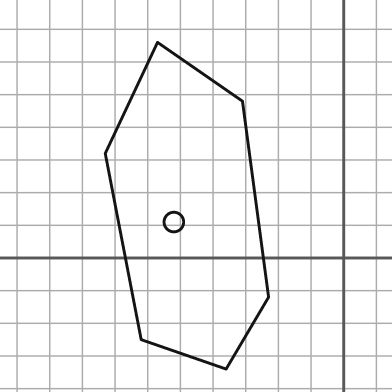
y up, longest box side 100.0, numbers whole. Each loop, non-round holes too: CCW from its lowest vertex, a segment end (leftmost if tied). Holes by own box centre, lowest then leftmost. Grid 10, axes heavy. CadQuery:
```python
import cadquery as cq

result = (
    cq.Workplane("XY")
    .moveTo(-36.0, -34.0)
    .lineTo(-23.0, -12.0)
    .lineTo(-31.0, 48.0)
    .lineTo(-57.0, 66.0)
    .lineTo(-73.0, 32.0)
    .lineTo(-62.0, -25.0)
    .close()
    .moveTo(-52.0, 11.0)
    .circle(3.0)
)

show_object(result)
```